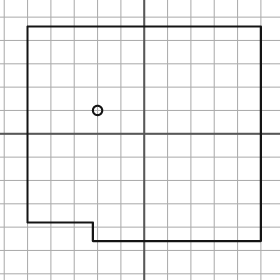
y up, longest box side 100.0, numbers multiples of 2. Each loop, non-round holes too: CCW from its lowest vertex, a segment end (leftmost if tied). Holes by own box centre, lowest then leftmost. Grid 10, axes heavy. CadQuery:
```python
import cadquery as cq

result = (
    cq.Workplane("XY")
    .moveTo(-22.0, -46.0)
    .lineTo(50.0, -46.0)
    .lineTo(50.0, 46.0)
    .lineTo(-50.0, 46.0)
    .lineTo(-50.0, -38.0)
    .lineTo(-22.0, -38.0)
    .close()
    .moveTo(-20.0, 10.0)
    .circle(2.0)
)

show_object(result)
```